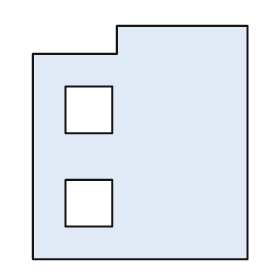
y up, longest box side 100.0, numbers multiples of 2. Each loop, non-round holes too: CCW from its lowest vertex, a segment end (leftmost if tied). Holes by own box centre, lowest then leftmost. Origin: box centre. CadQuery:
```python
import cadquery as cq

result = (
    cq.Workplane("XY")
    .moveTo(-46.0, -50.0)
    .lineTo(46.0, -50.0)
    .lineTo(46.0, 50.0)
    .lineTo(-10.0, 50.0)
    .lineTo(-10.0, 38.0)
    .lineTo(-46.0, 38.0)
    .close()
    .moveTo(-32.0, -36.0)
    .lineTo(-12.0, -36.0)
    .lineTo(-12.0, -16.0)
    .lineTo(-32.0, -16.0)
    .close()
    .moveTo(-32.0, 4.0)
    .lineTo(-12.0, 4.0)
    .lineTo(-12.0, 24.0)
    .lineTo(-32.0, 24.0)
    .close()
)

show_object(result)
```